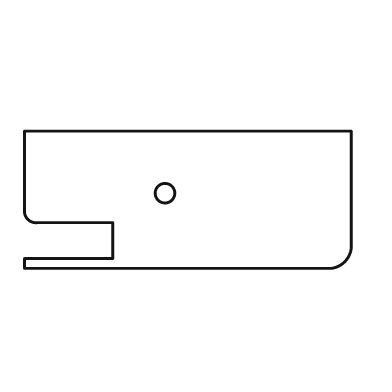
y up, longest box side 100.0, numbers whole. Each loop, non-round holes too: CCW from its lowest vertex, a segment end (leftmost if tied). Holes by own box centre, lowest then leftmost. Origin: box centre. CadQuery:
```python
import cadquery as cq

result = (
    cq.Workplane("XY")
    .moveTo(-50.0, -21.0)
    .lineTo(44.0, -21.0)
    .threePointArc((48.0, -19.0), (50.0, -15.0))
    .lineTo(50.0, 21.0)
    .lineTo(-50.0, 21.0)
    .lineTo(-50.0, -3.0)
    .threePointArc((-49.0, -6.0), (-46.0, -7.0))
    .lineTo(-23.0, -7.0)
    .lineTo(-23.0, -18.0)
    .lineTo(-50.0, -18.0)
    .close()
    .moveTo(-7.0, 2.0)
    .circle(3.0)
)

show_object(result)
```